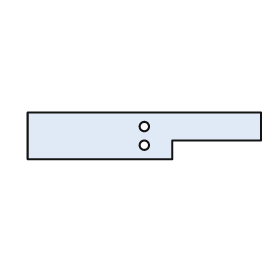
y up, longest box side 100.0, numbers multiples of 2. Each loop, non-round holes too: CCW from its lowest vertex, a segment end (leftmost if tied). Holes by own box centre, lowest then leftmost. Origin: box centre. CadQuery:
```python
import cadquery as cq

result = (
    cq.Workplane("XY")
    .moveTo(-50.0, -10.0)
    .lineTo(12.0, -10.0)
    .lineTo(12.0, -2.0)
    .lineTo(50.0, -2.0)
    .lineTo(50.0, 10.0)
    .lineTo(-50.0, 10.0)
    .close()
    .moveTo(0.0, -4.0)
    .circle(2.0)
    .moveTo(0.0, 4.0)
    .circle(2.0)
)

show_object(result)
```